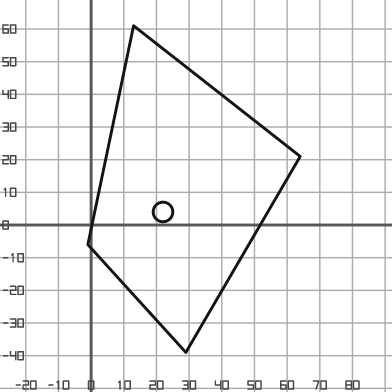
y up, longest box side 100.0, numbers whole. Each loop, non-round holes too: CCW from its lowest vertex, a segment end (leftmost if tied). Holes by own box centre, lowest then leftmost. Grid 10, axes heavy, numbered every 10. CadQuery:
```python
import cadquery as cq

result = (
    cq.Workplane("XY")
    .moveTo(29.0, -39.0)
    .lineTo(64.0, 21.0)
    .lineTo(13.0, 61.0)
    .lineTo(-1.0, -6.0)
    .close()
    .moveTo(22.0, 4.0)
    .circle(3.0)
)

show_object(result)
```